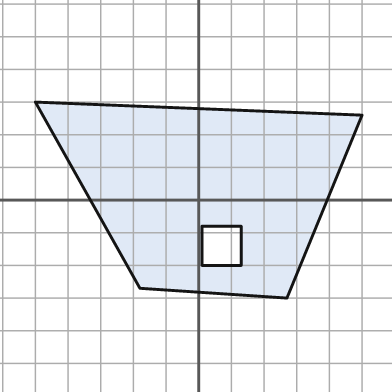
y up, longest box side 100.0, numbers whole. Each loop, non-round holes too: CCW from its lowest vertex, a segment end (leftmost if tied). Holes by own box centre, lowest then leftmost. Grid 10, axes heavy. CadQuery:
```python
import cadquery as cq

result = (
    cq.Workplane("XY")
    .moveTo(27.0, -30.0)
    .lineTo(50.0, 26.0)
    .lineTo(-50.0, 30.0)
    .lineTo(-18.0, -27.0)
    .close()
    .moveTo(1.0, -20.0)
    .lineTo(13.0, -20.0)
    .lineTo(13.0, -8.0)
    .lineTo(1.0, -8.0)
    .close()
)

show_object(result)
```